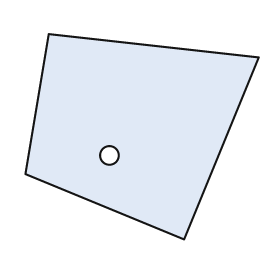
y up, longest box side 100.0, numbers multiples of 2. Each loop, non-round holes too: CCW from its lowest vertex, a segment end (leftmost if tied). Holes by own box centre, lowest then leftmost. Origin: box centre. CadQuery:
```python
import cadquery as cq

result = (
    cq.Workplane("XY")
    .moveTo(18.0, -44.0)
    .lineTo(50.0, 34.0)
    .lineTo(-40.0, 44.0)
    .lineTo(-50.0, -16.0)
    .close()
    .moveTo(-14.0, -8.0)
    .circle(4.0)
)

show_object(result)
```